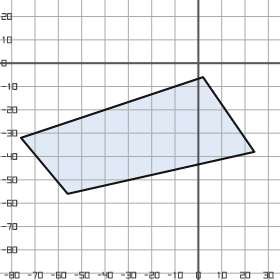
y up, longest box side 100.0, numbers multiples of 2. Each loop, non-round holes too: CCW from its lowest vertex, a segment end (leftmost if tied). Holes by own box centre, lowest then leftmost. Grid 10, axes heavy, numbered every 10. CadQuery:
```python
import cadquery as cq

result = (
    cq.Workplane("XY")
    .moveTo(-56.0, -56.0)
    .lineTo(24.0, -38.0)
    .lineTo(2.0, -6.0)
    .lineTo(-76.0, -32.0)
    .close()
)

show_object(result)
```